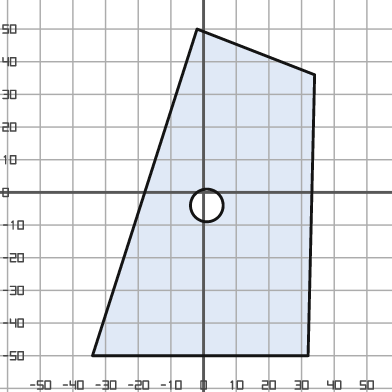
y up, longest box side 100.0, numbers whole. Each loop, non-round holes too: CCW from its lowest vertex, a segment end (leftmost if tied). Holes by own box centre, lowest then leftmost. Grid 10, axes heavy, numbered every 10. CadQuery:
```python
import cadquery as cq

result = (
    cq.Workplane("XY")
    .moveTo(-34.0, -50.0)
    .lineTo(32.0, -50.0)
    .lineTo(34.0, 36.0)
    .lineTo(-2.0, 50.0)
    .close()
    .moveTo(1.0, -4.0)
    .circle(5.0)
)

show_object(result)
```